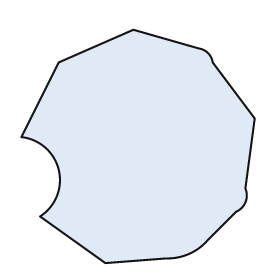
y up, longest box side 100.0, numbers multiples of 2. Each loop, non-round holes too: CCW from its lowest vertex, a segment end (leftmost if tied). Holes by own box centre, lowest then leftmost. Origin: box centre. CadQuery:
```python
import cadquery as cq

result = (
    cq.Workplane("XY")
    .moveTo(-14.0, -50.0)
    .lineTo(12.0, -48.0)
    .threePointArc((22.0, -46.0), (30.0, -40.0))
    .lineTo(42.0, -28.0)
    .threePointArc((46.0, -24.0), (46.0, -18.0))
    .lineTo(50.0, 12.0)
    .lineTo(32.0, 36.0)
    .threePointArc((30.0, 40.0), (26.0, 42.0))
    .lineTo(-2.0, 50.0)
    .lineTo(-34.0, 36.0)
    .lineTo(-50.0, 4.0)
    .threePointArc((-34.0, -10.0), (-42.0, -30.0))
    .close()
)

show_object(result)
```